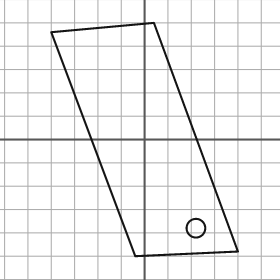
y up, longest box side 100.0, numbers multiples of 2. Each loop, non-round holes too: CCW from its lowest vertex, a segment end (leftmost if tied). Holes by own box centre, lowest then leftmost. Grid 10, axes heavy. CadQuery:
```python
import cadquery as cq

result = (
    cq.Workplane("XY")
    .moveTo(-4.0, -50.0)
    .lineTo(40.0, -48.0)
    .lineTo(4.0, 50.0)
    .lineTo(-40.0, 46.0)
    .close()
    .moveTo(22.0, -38.0)
    .circle(4.0)
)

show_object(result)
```